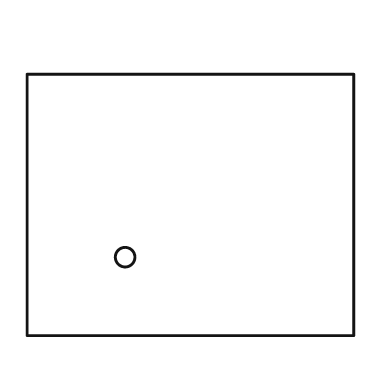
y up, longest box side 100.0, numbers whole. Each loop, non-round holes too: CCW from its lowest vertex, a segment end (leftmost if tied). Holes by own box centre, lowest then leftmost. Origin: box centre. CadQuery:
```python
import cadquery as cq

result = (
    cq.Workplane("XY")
    .moveTo(-50.0, -40.0)
    .lineTo(50.0, -40.0)
    .lineTo(50.0, 40.0)
    .lineTo(-50.0, 40.0)
    .close()
    .moveTo(-20.0, -16.0)
    .circle(3.0)
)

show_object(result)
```